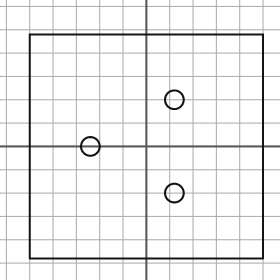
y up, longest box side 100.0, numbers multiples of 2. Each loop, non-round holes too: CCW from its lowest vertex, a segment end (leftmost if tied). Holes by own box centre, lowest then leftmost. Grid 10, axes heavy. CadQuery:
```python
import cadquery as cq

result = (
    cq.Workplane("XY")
    .moveTo(-50.0, -48.0)
    .lineTo(50.0, -48.0)
    .lineTo(50.0, 48.0)
    .lineTo(-50.0, 48.0)
    .close()
    .moveTo(12.0, -20.0)
    .circle(4.0)
    .moveTo(-24.0, 0.0)
    .circle(4.0)
    .moveTo(12.0, 20.0)
    .circle(4.0)
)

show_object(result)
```